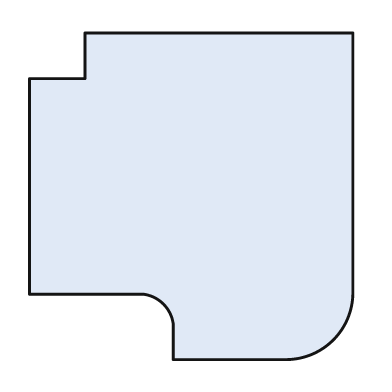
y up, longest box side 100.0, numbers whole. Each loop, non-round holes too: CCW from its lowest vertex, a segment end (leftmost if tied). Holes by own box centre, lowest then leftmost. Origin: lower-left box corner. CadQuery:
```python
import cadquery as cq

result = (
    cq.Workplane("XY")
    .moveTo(44.0, 0.0)
    .lineTo(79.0, 0.0)
    .threePointArc((93.0, 6.0), (99.0, 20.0))
    .lineTo(99.0, 100.0)
    .lineTo(17.0, 100.0)
    .lineTo(17.0, 86.0)
    .lineTo(0.0, 86.0)
    .lineTo(0.0, 20.0)
    .lineTo(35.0, 20.0)
    .threePointArc((41.0, 17.0), (44.0, 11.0))
    .close()
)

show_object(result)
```